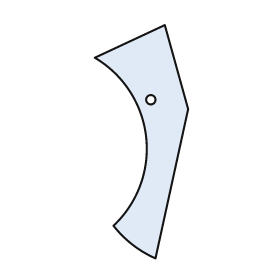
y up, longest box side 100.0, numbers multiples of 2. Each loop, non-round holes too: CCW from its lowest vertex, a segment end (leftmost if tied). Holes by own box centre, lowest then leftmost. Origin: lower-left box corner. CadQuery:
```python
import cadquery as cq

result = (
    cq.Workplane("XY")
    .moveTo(26.0, 0.0)
    .lineTo(40.0, 64.0)
    .lineTo(30.0, 100.0)
    .lineTo(0.0, 86.0)
    .threePointArc((22.0, 52.0), (8.0, 14.0))
    .threePointArc((16.0, 6.0), (26.0, 0.0))
    .close()
    .moveTo(24.0, 68.0)
    .circle(2.0)
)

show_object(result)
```